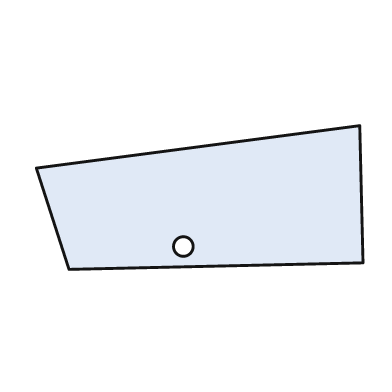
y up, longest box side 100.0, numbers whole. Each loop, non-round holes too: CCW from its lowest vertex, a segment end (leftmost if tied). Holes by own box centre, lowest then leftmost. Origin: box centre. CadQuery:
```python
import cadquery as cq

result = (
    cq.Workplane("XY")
    .moveTo(-40.0, -22.0)
    .lineTo(50.0, -20.0)
    .lineTo(49.0, 22.0)
    .lineTo(-50.0, 9.0)
    .close()
    .moveTo(-5.0, -15.0)
    .circle(3.0)
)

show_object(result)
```